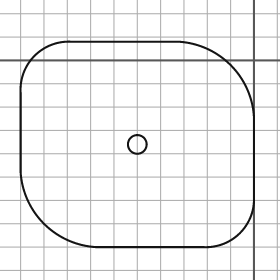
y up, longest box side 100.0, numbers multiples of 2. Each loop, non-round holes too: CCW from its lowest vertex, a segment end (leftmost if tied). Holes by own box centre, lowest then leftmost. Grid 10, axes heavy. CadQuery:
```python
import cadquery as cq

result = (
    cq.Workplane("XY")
    .moveTo(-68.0, -80.0)
    .lineTo(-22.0, -80.0)
    .threePointArc((-6.0, -74.0), (0.0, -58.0))
    .lineTo(0.0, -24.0)
    .threePointArc((-10.0, -2.0), (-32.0, 8.0))
    .lineTo(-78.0, 8.0)
    .threePointArc((-94.0, 2.0), (-100.0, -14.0))
    .lineTo(-100.0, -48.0)
    .threePointArc((-90.0, -70.0), (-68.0, -80.0))
    .close()
    .moveTo(-50.0, -36.0)
    .circle(4.0)
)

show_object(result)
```